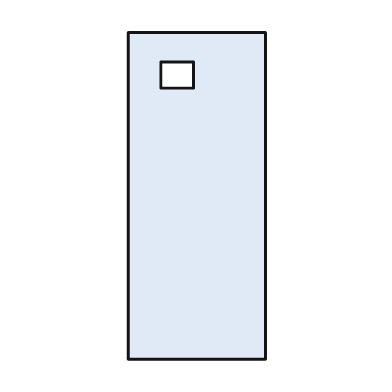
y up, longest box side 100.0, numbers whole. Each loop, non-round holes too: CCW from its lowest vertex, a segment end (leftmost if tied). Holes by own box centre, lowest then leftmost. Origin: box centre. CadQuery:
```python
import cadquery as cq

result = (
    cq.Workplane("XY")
    .moveTo(-21.0, -50.0)
    .lineTo(21.0, -50.0)
    .lineTo(21.0, 50.0)
    .lineTo(-21.0, 50.0)
    .close()
    .moveTo(-11.0, 33.0)
    .lineTo(-1.0, 33.0)
    .lineTo(-1.0, 41.0)
    .lineTo(-11.0, 41.0)
    .close()
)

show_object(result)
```